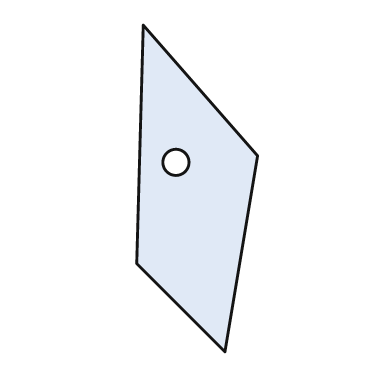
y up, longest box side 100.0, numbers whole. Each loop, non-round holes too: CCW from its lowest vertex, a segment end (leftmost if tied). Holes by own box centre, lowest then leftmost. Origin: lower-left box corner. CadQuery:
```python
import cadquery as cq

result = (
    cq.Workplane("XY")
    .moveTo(27.0, 0.0)
    .lineTo(37.0, 60.0)
    .lineTo(2.0, 100.0)
    .lineTo(0.0, 27.0)
    .close()
    .moveTo(12.0, 58.0)
    .circle(4.0)
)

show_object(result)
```